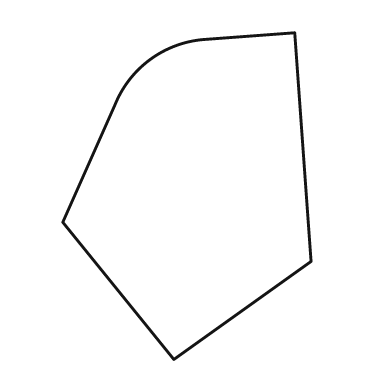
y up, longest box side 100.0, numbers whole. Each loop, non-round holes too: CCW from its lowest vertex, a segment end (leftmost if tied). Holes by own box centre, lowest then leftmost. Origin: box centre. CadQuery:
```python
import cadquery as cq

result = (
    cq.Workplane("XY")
    .moveTo(-4.0, -50.0)
    .lineTo(38.0, -20.0)
    .lineTo(33.0, 50.0)
    .lineTo(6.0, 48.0)
    .threePointArc((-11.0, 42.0), (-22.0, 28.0))
    .lineTo(-38.0, -8.0)
    .close()
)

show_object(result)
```